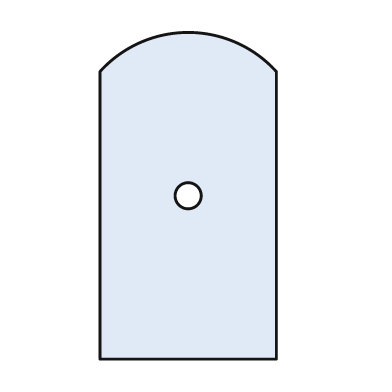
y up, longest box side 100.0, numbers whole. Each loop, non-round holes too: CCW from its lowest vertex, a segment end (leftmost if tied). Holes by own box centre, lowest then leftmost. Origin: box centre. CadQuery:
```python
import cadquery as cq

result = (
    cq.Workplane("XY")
    .moveTo(-27.0, -50.0)
    .lineTo(27.0, -50.0)
    .lineTo(27.0, 38.0)
    .threePointArc((0.0, 50.0), (-27.0, 38.0))
    .close()
    .moveTo(0.0, 0.0)
    .circle(4.0)
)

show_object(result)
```